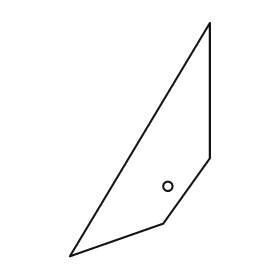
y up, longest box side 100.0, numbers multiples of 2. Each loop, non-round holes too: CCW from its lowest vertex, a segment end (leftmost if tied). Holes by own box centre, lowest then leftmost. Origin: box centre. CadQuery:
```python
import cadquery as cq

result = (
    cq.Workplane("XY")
    .moveTo(-30.0, -50.0)
    .lineTo(10.0, -36.0)
    .lineTo(30.0, -8.0)
    .lineTo(30.0, 50.0)
    .close()
    .moveTo(12.0, -20.0)
    .circle(2.0)
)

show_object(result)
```